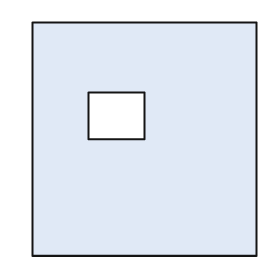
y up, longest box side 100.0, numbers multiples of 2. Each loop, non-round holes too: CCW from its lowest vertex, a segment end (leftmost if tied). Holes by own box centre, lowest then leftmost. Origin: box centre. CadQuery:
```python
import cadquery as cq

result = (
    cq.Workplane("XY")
    .moveTo(-48.0, -50.0)
    .lineTo(48.0, -50.0)
    .lineTo(48.0, 50.0)
    .lineTo(-48.0, 50.0)
    .close()
    .moveTo(-24.0, 0.0)
    .lineTo(0.0, 0.0)
    .lineTo(0.0, 20.0)
    .lineTo(-24.0, 20.0)
    .close()
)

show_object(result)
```